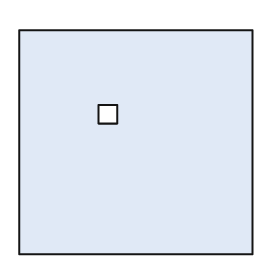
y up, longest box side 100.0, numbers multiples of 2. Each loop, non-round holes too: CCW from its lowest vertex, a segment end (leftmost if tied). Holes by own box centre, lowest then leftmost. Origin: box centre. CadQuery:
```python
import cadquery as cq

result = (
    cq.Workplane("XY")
    .moveTo(-50.0, -48.0)
    .lineTo(50.0, -48.0)
    .lineTo(50.0, 48.0)
    .lineTo(-50.0, 48.0)
    .close()
    .moveTo(-16.0, 8.0)
    .lineTo(-8.0, 8.0)
    .lineTo(-8.0, 16.0)
    .lineTo(-16.0, 16.0)
    .close()
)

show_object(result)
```